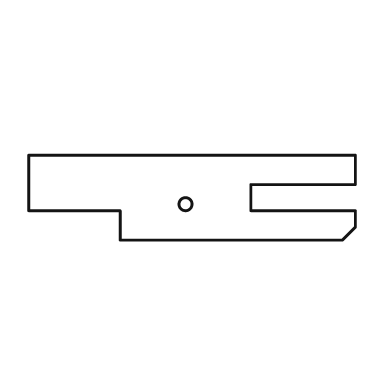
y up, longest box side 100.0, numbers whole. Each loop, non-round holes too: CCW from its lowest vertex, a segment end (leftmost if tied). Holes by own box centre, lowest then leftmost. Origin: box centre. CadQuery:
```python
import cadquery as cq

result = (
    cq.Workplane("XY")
    .moveTo(-22.0, -13.0)
    .lineTo(46.0, -13.0)
    .lineTo(50.0, -9.0)
    .lineTo(50.0, -4.0)
    .lineTo(18.0, -4.0)
    .lineTo(18.0, 4.0)
    .lineTo(50.0, 4.0)
    .lineTo(50.0, 13.0)
    .lineTo(-50.0, 13.0)
    .lineTo(-50.0, -4.0)
    .lineTo(-22.0, -4.0)
    .close()
    .moveTo(-2.0, -2.0)
    .circle(2.0)
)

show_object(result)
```